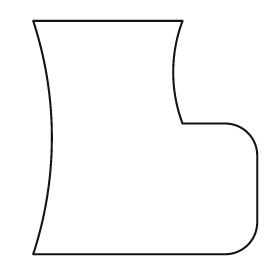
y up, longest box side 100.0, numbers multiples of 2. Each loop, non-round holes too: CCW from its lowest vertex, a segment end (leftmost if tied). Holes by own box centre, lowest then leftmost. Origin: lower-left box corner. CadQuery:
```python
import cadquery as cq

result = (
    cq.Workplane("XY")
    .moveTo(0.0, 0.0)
    .lineTo(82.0, 0.0)
    .threePointArc((92.0, 4.0), (96.0, 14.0))
    .lineTo(96.0, 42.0)
    .threePointArc((92.0, 52.0), (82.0, 56.0))
    .lineTo(64.0, 56.0)
    .threePointArc((60.0, 78.0), (64.0, 100.0))
    .lineTo(0.0, 100.0)
    .threePointArc((8.0, 50.0), (0.0, 0.0))
    .close()
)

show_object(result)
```